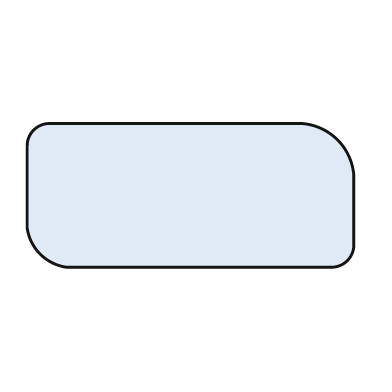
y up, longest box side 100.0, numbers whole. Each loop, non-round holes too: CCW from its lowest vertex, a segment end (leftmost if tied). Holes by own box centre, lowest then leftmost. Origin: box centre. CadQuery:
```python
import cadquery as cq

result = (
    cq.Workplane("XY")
    .moveTo(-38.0, -22.0)
    .lineTo(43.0, -22.0)
    .threePointArc((48.0, -20.0), (50.0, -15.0))
    .lineTo(50.0, 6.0)
    .threePointArc((45.0, 17.0), (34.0, 22.0))
    .lineTo(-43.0, 22.0)
    .threePointArc((-48.0, 20.0), (-50.0, 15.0))
    .lineTo(-50.0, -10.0)
    .threePointArc((-46.0, -18.0), (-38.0, -22.0))
    .close()
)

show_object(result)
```